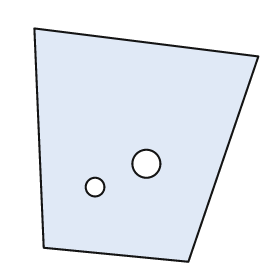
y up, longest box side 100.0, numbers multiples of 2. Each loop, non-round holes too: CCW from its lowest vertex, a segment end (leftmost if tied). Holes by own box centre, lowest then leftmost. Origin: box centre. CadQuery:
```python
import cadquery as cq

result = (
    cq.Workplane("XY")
    .moveTo(18.0, -50.0)
    .lineTo(48.0, 38.0)
    .lineTo(-48.0, 50.0)
    .lineTo(-44.0, -44.0)
    .close()
    .moveTo(-22.0, -18.0)
    .circle(4.0)
    .moveTo(0.0, -8.0)
    .circle(6.0)
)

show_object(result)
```